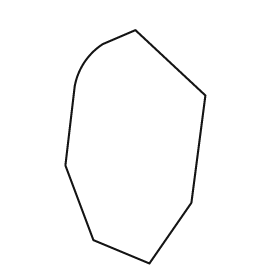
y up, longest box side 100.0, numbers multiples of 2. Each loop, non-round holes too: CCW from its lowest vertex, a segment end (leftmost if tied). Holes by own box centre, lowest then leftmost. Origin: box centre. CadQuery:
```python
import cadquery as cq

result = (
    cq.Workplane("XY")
    .moveTo(6.0, -50.0)
    .lineTo(24.0, -24.0)
    .lineTo(30.0, 22.0)
    .lineTo(0.0, 50.0)
    .lineTo(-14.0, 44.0)
    .threePointArc((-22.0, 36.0), (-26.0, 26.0))
    .lineTo(-30.0, -8.0)
    .lineTo(-18.0, -40.0)
    .close()
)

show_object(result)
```